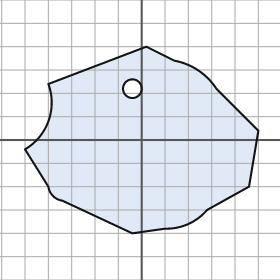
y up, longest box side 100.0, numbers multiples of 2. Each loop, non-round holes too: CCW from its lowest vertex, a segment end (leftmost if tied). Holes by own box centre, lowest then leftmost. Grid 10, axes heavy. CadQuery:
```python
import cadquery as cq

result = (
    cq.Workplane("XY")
    .moveTo(-4.0, -40.0)
    .lineTo(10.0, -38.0)
    .threePointArc((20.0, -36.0), (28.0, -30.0))
    .lineTo(46.0, -20.0)
    .lineTo(50.0, 4.0)
    .lineTo(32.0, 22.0)
    .threePointArc((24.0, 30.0), (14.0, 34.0))
    .lineTo(2.0, 40.0)
    .lineTo(-40.0, 24.0)
    .threePointArc((-40.0, 8.0), (-50.0, -4.0))
    .lineTo(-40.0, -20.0)
    .threePointArc((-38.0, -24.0), (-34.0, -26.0))
    .close()
    .moveTo(-4.0, 22.0)
    .circle(4.0)
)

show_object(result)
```